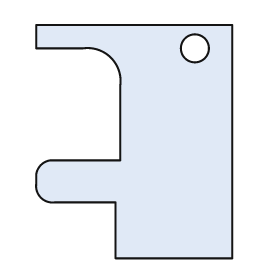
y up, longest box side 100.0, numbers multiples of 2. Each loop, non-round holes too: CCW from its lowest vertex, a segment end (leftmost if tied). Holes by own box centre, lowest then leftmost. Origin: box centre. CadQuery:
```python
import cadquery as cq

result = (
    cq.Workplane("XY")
    .moveTo(-8.0, -50.0)
    .lineTo(42.0, -50.0)
    .lineTo(42.0, 50.0)
    .lineTo(-42.0, 50.0)
    .lineTo(-42.0, 40.0)
    .lineTo(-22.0, 40.0)
    .threePointArc((-10.0, 36.0), (-6.0, 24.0))
    .lineTo(-6.0, -8.0)
    .lineTo(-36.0, -8.0)
    .threePointArc((-40.0, -10.0), (-42.0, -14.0))
    .lineTo(-42.0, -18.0)
    .threePointArc((-40.0, -24.0), (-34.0, -26.0))
    .lineTo(-8.0, -26.0)
    .close()
    .moveTo(26.0, 40.0)
    .circle(6.0)
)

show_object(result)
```